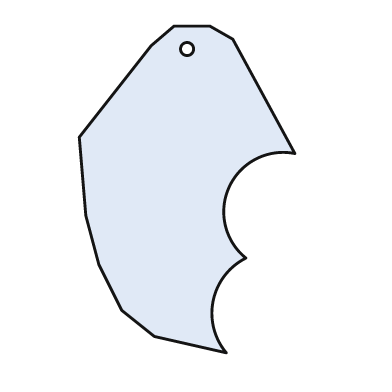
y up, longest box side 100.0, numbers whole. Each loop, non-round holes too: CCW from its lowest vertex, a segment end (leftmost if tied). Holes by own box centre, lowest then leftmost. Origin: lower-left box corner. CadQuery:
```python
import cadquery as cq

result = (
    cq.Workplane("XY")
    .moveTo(45.0, 0.0)
    .threePointArc((41.0, 16.0), (51.0, 29.0))
    .threePointArc((46.0, 51.0), (66.0, 61.0))
    .lineTo(47.0, 96.0)
    .lineTo(40.0, 100.0)
    .lineTo(29.0, 100.0)
    .lineTo(22.0, 94.0)
    .lineTo(0.0, 66.0)
    .lineTo(2.0, 42.0)
    .lineTo(6.0, 27.0)
    .lineTo(13.0, 13.0)
    .lineTo(23.0, 5.0)
    .close()
    .moveTo(33.0, 93.0)
    .circle(2.0)
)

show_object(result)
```